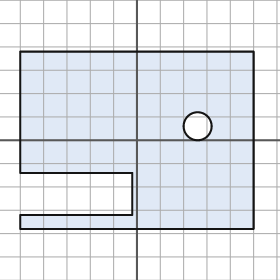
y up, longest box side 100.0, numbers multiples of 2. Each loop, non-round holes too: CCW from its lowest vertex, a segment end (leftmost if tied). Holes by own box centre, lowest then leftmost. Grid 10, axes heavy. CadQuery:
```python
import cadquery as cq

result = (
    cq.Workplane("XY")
    .moveTo(-50.0, -38.0)
    .lineTo(50.0, -38.0)
    .lineTo(50.0, 38.0)
    .lineTo(-50.0, 38.0)
    .lineTo(-50.0, -14.0)
    .lineTo(-2.0, -14.0)
    .lineTo(-2.0, -32.0)
    .lineTo(-50.0, -32.0)
    .close()
    .moveTo(26.0, 6.0)
    .circle(6.0)
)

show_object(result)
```